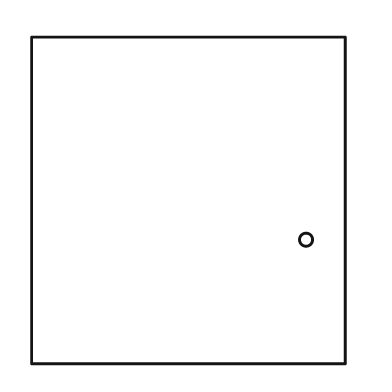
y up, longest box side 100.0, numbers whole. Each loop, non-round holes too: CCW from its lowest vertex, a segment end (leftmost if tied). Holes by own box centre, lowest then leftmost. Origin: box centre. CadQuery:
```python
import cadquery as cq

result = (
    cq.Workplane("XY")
    .moveTo(-48.0, -50.0)
    .lineTo(48.0, -50.0)
    .lineTo(48.0, 50.0)
    .lineTo(-48.0, 50.0)
    .close()
    .moveTo(36.0, -12.0)
    .circle(2.0)
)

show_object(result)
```